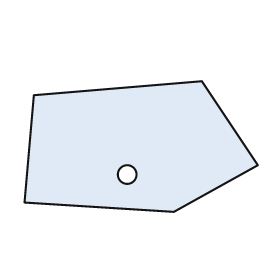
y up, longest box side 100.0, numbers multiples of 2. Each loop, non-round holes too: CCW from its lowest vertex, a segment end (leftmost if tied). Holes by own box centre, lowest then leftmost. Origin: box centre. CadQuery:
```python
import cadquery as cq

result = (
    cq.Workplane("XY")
    .moveTo(14.0, -28.0)
    .lineTo(50.0, -8.0)
    .lineTo(26.0, 28.0)
    .lineTo(-46.0, 22.0)
    .lineTo(-50.0, -24.0)
    .close()
    .moveTo(-6.0, -12.0)
    .circle(4.0)
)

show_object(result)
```